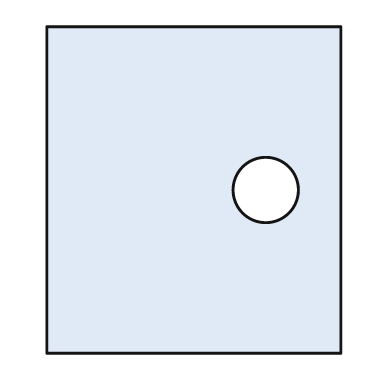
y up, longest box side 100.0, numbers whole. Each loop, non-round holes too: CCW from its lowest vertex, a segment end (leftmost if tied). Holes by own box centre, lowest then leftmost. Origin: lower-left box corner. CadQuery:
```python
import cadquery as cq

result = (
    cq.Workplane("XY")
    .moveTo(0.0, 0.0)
    .lineTo(90.0, 0.0)
    .lineTo(90.0, 100.0)
    .lineTo(0.0, 100.0)
    .close()
    .moveTo(67.0, 50.0)
    .circle(10.0)
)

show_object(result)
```